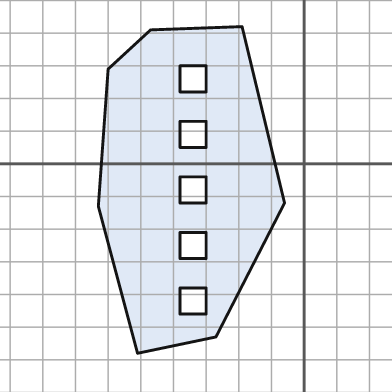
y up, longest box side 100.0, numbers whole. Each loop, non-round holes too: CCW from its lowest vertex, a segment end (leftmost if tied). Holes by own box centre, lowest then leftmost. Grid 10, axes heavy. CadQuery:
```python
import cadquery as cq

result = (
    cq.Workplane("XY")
    .moveTo(-51.0, -58.0)
    .lineTo(-27.0, -53.0)
    .lineTo(-6.0, -12.0)
    .lineTo(-19.0, 42.0)
    .lineTo(-47.0, 41.0)
    .lineTo(-60.0, 29.0)
    .lineTo(-63.0, -13.0)
    .close()
    .moveTo(-38.0, -46.0)
    .lineTo(-30.0, -46.0)
    .lineTo(-30.0, -38.0)
    .lineTo(-38.0, -38.0)
    .close()
    .moveTo(-38.0, -29.0)
    .lineTo(-30.0, -29.0)
    .lineTo(-30.0, -21.0)
    .lineTo(-38.0, -21.0)
    .close()
    .moveTo(-38.0, -12.0)
    .lineTo(-30.0, -12.0)
    .lineTo(-30.0, -4.0)
    .lineTo(-38.0, -4.0)
    .close()
    .moveTo(-38.0, 5.0)
    .lineTo(-30.0, 5.0)
    .lineTo(-30.0, 13.0)
    .lineTo(-38.0, 13.0)
    .close()
    .moveTo(-38.0, 22.0)
    .lineTo(-30.0, 22.0)
    .lineTo(-30.0, 30.0)
    .lineTo(-38.0, 30.0)
    .close()
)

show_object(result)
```